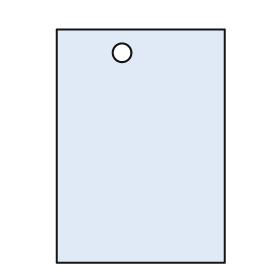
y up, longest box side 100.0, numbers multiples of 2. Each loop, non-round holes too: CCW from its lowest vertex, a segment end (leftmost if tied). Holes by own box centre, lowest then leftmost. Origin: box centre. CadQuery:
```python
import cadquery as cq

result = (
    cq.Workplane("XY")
    .moveTo(-36.0, -50.0)
    .lineTo(36.0, -50.0)
    .lineTo(36.0, 50.0)
    .lineTo(-36.0, 50.0)
    .close()
    .moveTo(-8.0, 40.0)
    .circle(4.0)
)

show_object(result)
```